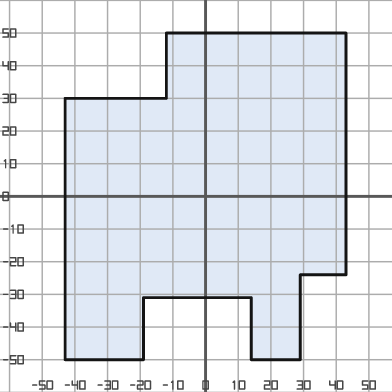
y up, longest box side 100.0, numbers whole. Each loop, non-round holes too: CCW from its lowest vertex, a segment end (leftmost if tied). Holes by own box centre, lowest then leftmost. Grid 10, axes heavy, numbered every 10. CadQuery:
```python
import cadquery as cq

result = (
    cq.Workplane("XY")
    .moveTo(-43.0, -50.0)
    .lineTo(-19.0, -50.0)
    .lineTo(-19.0, -31.0)
    .lineTo(14.0, -31.0)
    .lineTo(14.0, -50.0)
    .lineTo(29.0, -50.0)
    .lineTo(29.0, -24.0)
    .lineTo(43.0, -24.0)
    .lineTo(43.0, 50.0)
    .lineTo(-12.0, 50.0)
    .lineTo(-12.0, 30.0)
    .lineTo(-43.0, 30.0)
    .close()
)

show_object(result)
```